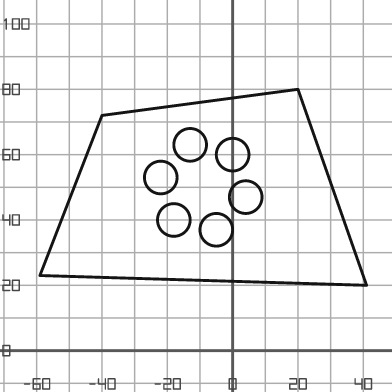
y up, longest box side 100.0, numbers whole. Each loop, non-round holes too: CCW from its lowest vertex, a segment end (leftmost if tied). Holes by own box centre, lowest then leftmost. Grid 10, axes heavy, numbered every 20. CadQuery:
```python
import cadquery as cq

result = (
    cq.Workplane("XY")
    .moveTo(41.0, 20.0)
    .lineTo(20.0, 80.0)
    .lineTo(-40.0, 72.0)
    .lineTo(-59.0, 23.0)
    .close()
    .moveTo(-5.0, 37.0)
    .circle(5.0)
    .moveTo(-18.0, 40.0)
    .circle(5.0)
    .moveTo(4.0, 47.0)
    .circle(5.0)
    .moveTo(-22.0, 53.0)
    .circle(5.0)
    .moveTo(0.0, 60.0)
    .circle(5.0)
    .moveTo(-13.0, 63.0)
    .circle(5.0)
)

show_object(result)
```